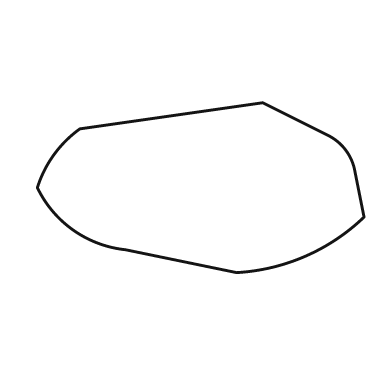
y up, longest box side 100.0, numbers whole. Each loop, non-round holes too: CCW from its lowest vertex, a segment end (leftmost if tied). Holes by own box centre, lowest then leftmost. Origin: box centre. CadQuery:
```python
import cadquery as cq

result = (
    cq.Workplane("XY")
    .moveTo(11.0, -26.0)
    .threePointArc((32.0, -21.0), (50.0, -9.0))
    .lineTo(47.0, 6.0)
    .threePointArc((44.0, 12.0), (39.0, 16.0))
    .lineTo(19.0, 26.0)
    .lineTo(-37.0, 18.0)
    .threePointArc((-45.0, 10.0), (-50.0, 0.0))
    .threePointArc((-39.0, -13.0), (-23.0, -19.0))
    .close()
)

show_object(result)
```